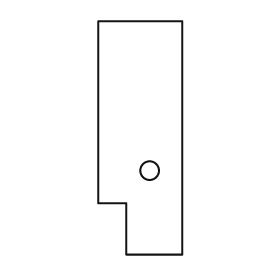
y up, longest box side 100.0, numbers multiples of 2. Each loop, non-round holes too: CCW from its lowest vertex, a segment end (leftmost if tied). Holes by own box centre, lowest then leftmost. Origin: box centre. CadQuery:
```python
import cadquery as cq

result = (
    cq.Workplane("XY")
    .moveTo(-6.0, -50.0)
    .lineTo(18.0, -50.0)
    .lineTo(18.0, 50.0)
    .lineTo(-18.0, 50.0)
    .lineTo(-18.0, -28.0)
    .lineTo(-6.0, -28.0)
    .close()
    .moveTo(4.0, -14.0)
    .circle(4.0)
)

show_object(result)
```